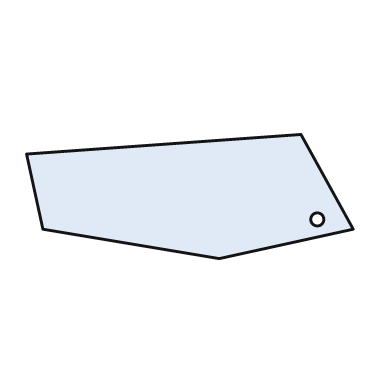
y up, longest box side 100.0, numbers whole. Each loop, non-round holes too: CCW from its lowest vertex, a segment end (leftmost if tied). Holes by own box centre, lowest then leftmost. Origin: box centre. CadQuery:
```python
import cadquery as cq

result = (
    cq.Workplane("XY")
    .moveTo(9.0, -19.0)
    .lineTo(50.0, -10.0)
    .lineTo(34.0, 19.0)
    .lineTo(-50.0, 13.0)
    .lineTo(-45.0, -10.0)
    .close()
    .moveTo(39.0, -7.0)
    .circle(2.0)
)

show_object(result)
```